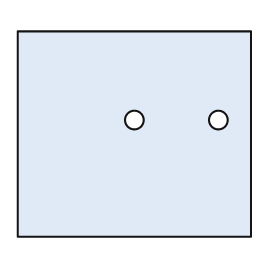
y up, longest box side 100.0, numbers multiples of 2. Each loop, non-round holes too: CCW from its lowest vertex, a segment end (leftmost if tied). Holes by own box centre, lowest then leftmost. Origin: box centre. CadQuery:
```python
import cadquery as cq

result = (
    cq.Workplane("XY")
    .moveTo(-50.0, -44.0)
    .lineTo(50.0, -44.0)
    .lineTo(50.0, 44.0)
    .lineTo(-50.0, 44.0)
    .close()
    .moveTo(0.0, 6.0)
    .circle(4.0)
    .moveTo(36.0, 6.0)
    .circle(4.0)
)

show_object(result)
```